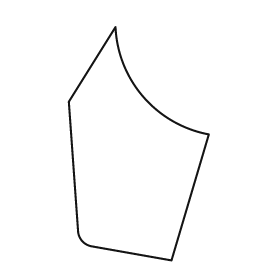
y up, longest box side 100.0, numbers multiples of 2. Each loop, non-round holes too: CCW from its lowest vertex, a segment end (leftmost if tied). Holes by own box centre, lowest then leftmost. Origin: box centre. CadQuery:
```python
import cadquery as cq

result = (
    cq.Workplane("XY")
    .moveTo(14.0, -50.0)
    .lineTo(30.0, 4.0)
    .threePointArc((2.0, 20.0), (-10.0, 50.0))
    .lineTo(-30.0, 18.0)
    .lineTo(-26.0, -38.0)
    .threePointArc((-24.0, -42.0), (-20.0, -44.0))
    .close()
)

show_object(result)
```